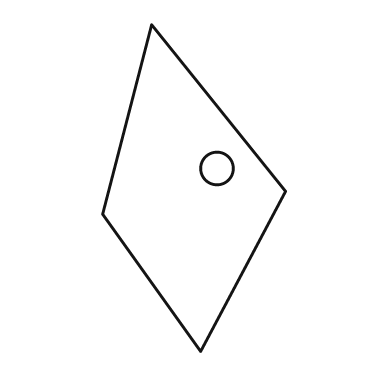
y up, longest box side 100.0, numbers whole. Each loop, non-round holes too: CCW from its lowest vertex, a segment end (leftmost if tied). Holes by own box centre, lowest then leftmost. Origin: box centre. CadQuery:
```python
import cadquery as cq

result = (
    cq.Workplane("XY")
    .moveTo(2.0, -50.0)
    .lineTo(28.0, -1.0)
    .lineTo(-13.0, 50.0)
    .lineTo(-28.0, -8.0)
    .close()
    .moveTo(7.0, 6.0)
    .circle(5.0)
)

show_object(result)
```